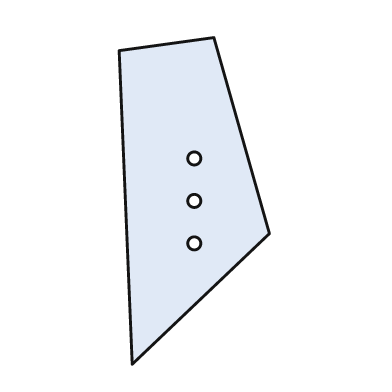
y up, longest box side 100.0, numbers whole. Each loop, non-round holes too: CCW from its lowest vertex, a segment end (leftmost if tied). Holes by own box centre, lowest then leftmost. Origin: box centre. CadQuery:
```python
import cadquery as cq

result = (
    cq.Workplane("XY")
    .moveTo(-19.0, -50.0)
    .lineTo(23.0, -10.0)
    .lineTo(6.0, 50.0)
    .lineTo(-23.0, 46.0)
    .close()
    .moveTo(0.0, -13.0)
    .circle(2.0)
    .moveTo(0.0, 0.0)
    .circle(2.0)
    .moveTo(0.0, 13.0)
    .circle(2.0)
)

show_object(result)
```